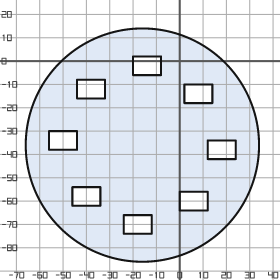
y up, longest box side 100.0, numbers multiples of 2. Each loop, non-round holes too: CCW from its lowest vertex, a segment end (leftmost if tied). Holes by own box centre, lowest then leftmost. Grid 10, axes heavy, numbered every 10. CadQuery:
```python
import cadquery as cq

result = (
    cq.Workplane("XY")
    .moveTo(-16.0, -36.0)
    .circle(50.0)
    .moveTo(-24.0, -74.0)
    .lineTo(-12.0, -74.0)
    .lineTo(-12.0, -66.0)
    .lineTo(-24.0, -66.0)
    .close()
    .moveTo(0.0, -64.0)
    .lineTo(12.0, -64.0)
    .lineTo(12.0, -56.0)
    .lineTo(0.0, -56.0)
    .close()
    .moveTo(-46.0, -62.0)
    .lineTo(-34.0, -62.0)
    .lineTo(-34.0, -54.0)
    .lineTo(-46.0, -54.0)
    .close()
    .moveTo(12.0, -42.0)
    .lineTo(24.0, -42.0)
    .lineTo(24.0, -34.0)
    .lineTo(12.0, -34.0)
    .close()
    .moveTo(-56.0, -38.0)
    .lineTo(-44.0, -38.0)
    .lineTo(-44.0, -30.0)
    .lineTo(-56.0, -30.0)
    .close()
    .moveTo(2.0, -18.0)
    .lineTo(14.0, -18.0)
    .lineTo(14.0, -10.0)
    .lineTo(2.0, -10.0)
    .close()
    .moveTo(-44.0, -16.0)
    .lineTo(-32.0, -16.0)
    .lineTo(-32.0, -8.0)
    .lineTo(-44.0, -8.0)
    .close()
    .moveTo(-20.0, -6.0)
    .lineTo(-8.0, -6.0)
    .lineTo(-8.0, 2.0)
    .lineTo(-20.0, 2.0)
    .close()
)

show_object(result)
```